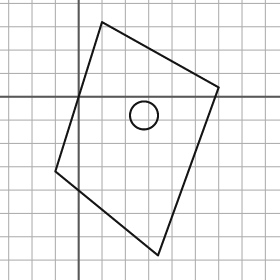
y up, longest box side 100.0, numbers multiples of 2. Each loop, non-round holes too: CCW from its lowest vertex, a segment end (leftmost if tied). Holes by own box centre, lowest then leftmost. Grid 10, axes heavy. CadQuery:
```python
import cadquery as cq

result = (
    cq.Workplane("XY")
    .moveTo(34.0, -68.0)
    .lineTo(60.0, 4.0)
    .lineTo(10.0, 32.0)
    .lineTo(-10.0, -32.0)
    .close()
    .moveTo(28.0, -8.0)
    .circle(6.0)
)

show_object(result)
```